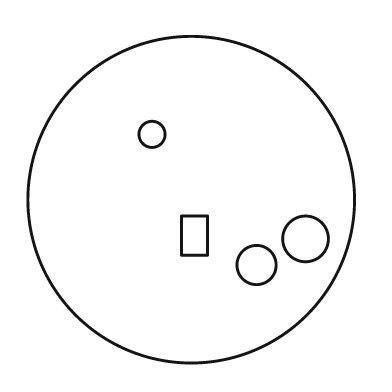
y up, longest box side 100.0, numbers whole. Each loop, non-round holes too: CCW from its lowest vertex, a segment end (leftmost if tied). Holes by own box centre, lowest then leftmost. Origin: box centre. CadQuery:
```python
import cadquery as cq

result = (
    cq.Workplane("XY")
    .moveTo(0.0, 0.0)
    .circle(50.0)
    .moveTo(20.0, -20.0)
    .circle(6.0)
    .moveTo(35.0, -12.0)
    .circle(7.0)
    .moveTo(-3.0, -17.0)
    .lineTo(5.0, -17.0)
    .lineTo(5.0, -5.0)
    .lineTo(-3.0, -5.0)
    .close()
    .moveTo(-12.0, 20.0)
    .circle(4.0)
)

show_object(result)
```